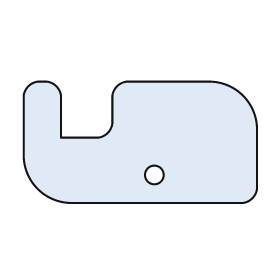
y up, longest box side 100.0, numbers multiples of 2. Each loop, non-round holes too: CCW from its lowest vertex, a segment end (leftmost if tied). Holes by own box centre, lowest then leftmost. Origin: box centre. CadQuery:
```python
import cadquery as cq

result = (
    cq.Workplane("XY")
    .moveTo(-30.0, -26.0)
    .lineTo(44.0, -26.0)
    .threePointArc((48.0, -24.0), (50.0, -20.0))
    .lineTo(50.0, 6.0)
    .threePointArc((44.0, 20.0), (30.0, 26.0))
    .lineTo(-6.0, 26.0)
    .threePointArc((-10.0, 24.0), (-12.0, 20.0))
    .lineTo(-12.0, 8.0)
    .threePointArc((-14.0, 4.0), (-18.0, 2.0))
    .lineTo(-34.0, 2.0)
    .lineTo(-34.0, 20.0)
    .threePointArc((-36.0, 24.0), (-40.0, 26.0))
    .lineTo(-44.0, 26.0)
    .threePointArc((-48.0, 24.0), (-50.0, 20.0))
    .lineTo(-50.0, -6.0)
    .threePointArc((-44.0, -20.0), (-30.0, -26.0))
    .close()
    .moveTo(6.0, -14.0)
    .circle(4.0)
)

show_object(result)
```